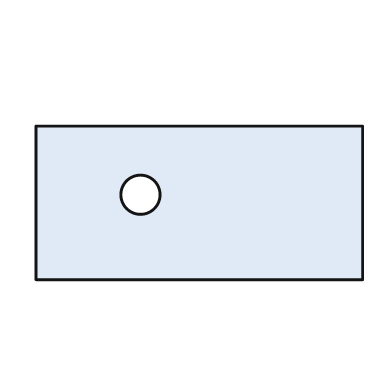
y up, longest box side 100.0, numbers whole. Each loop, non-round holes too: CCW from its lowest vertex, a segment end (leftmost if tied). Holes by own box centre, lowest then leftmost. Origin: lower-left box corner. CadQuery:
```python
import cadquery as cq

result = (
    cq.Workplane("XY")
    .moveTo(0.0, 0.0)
    .lineTo(100.0, 0.0)
    .lineTo(100.0, 47.0)
    .lineTo(0.0, 47.0)
    .close()
    .moveTo(32.0, 26.0)
    .circle(6.0)
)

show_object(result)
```